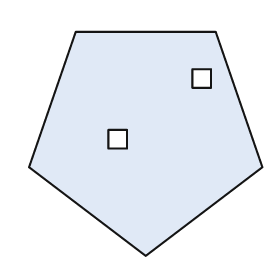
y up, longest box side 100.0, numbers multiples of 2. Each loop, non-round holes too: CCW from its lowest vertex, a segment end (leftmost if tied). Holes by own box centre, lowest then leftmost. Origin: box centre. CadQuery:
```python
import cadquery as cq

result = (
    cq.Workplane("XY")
    .moveTo(0.0, -48.0)
    .lineTo(50.0, -10.0)
    .lineTo(30.0, 48.0)
    .lineTo(-30.0, 48.0)
    .lineTo(-50.0, -10.0)
    .close()
    .moveTo(-16.0, -2.0)
    .lineTo(-8.0, -2.0)
    .lineTo(-8.0, 6.0)
    .lineTo(-16.0, 6.0)
    .close()
    .moveTo(20.0, 24.0)
    .lineTo(28.0, 24.0)
    .lineTo(28.0, 32.0)
    .lineTo(20.0, 32.0)
    .close()
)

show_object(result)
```